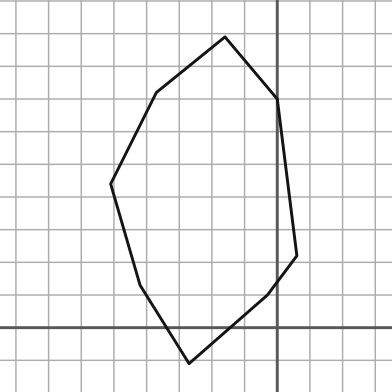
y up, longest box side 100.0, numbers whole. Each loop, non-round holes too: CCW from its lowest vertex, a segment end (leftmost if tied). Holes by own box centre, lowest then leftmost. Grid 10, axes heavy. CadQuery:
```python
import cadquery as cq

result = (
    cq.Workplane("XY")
    .moveTo(-27.0, -11.0)
    .lineTo(-3.0, 10.0)
    .lineTo(6.0, 22.0)
    .lineTo(0.0, 70.0)
    .lineTo(-16.0, 89.0)
    .lineTo(-37.0, 72.0)
    .lineTo(-51.0, 44.0)
    .lineTo(-42.0, 13.0)
    .close()
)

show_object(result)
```